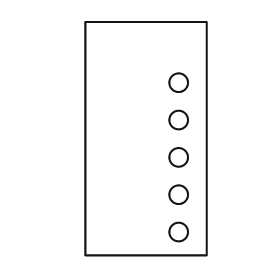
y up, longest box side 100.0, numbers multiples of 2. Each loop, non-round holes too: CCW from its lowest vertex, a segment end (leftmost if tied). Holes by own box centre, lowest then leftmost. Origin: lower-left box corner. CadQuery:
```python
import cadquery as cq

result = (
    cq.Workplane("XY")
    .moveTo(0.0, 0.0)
    .lineTo(52.0, 0.0)
    .lineTo(52.0, 100.0)
    .lineTo(0.0, 100.0)
    .close()
    .moveTo(40.0, 10.0)
    .circle(4.0)
    .moveTo(40.0, 26.0)
    .circle(4.0)
    .moveTo(40.0, 42.0)
    .circle(4.0)
    .moveTo(40.0, 58.0)
    .circle(4.0)
    .moveTo(40.0, 74.0)
    .circle(4.0)
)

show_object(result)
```